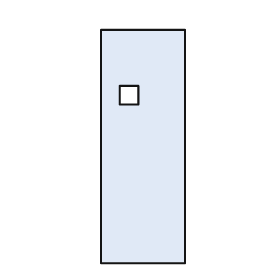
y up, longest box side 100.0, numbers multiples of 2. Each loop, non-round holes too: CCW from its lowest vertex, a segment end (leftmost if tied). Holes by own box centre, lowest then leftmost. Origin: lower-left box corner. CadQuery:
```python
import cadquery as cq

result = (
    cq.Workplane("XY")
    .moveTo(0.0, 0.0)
    .lineTo(36.0, 0.0)
    .lineTo(36.0, 100.0)
    .lineTo(0.0, 100.0)
    .close()
    .moveTo(8.0, 68.0)
    .lineTo(16.0, 68.0)
    .lineTo(16.0, 76.0)
    .lineTo(8.0, 76.0)
    .close()
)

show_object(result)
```